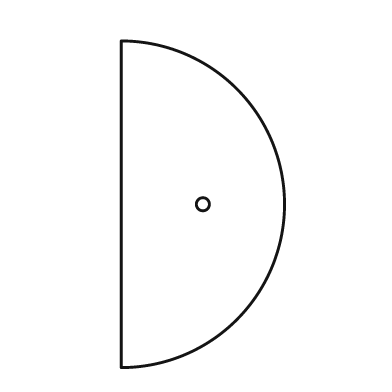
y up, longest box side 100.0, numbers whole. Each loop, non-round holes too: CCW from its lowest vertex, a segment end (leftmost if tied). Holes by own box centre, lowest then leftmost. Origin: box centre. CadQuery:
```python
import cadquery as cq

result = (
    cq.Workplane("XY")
    .moveTo(-25.0, -50.0)
    .threePointArc((25.0, 0.0), (-25.0, 50.0))
    .close()
    .moveTo(0.0, 0.0)
    .circle(2.0)
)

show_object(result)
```